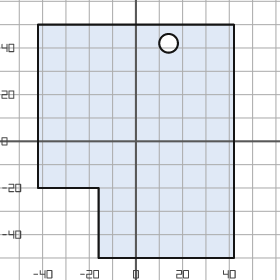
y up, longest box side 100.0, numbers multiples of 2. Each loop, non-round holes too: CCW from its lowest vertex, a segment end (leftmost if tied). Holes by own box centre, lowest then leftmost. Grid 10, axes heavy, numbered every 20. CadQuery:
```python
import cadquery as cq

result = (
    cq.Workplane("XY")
    .moveTo(-16.0, -50.0)
    .lineTo(42.0, -50.0)
    .lineTo(42.0, 50.0)
    .lineTo(-42.0, 50.0)
    .lineTo(-42.0, -20.0)
    .lineTo(-16.0, -20.0)
    .close()
    .moveTo(14.0, 42.0)
    .circle(4.0)
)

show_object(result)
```